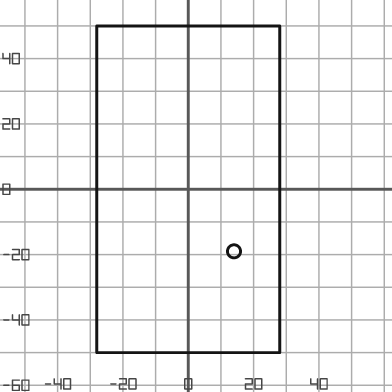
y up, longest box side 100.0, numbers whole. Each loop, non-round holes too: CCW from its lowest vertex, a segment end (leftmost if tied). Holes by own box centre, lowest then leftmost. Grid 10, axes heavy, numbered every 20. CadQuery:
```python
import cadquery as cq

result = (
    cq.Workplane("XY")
    .moveTo(-28.0, -50.0)
    .lineTo(28.0, -50.0)
    .lineTo(28.0, 50.0)
    .lineTo(-28.0, 50.0)
    .close()
    .moveTo(14.0, -19.0)
    .circle(2.0)
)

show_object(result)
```